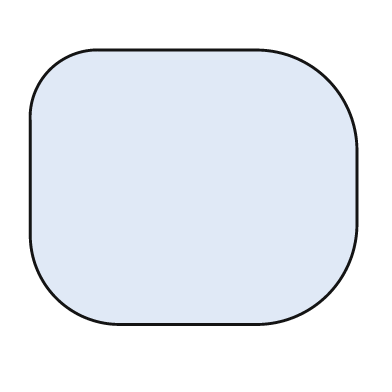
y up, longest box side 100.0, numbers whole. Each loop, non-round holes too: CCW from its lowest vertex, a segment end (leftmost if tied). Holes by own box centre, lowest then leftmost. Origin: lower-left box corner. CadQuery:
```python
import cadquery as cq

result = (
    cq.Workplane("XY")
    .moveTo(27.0, 0.0)
    .lineTo(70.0, 0.0)
    .threePointArc((91.0, 9.0), (100.0, 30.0))
    .lineTo(100.0, 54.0)
    .threePointArc((91.0, 75.0), (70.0, 84.0))
    .lineTo(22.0, 84.0)
    .threePointArc((6.0, 78.0), (0.0, 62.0))
    .lineTo(0.0, 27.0)
    .threePointArc((8.0, 8.0), (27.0, 0.0))
    .close()
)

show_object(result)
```